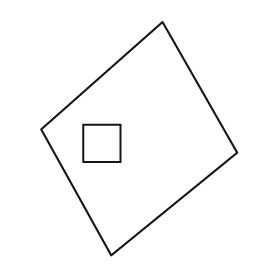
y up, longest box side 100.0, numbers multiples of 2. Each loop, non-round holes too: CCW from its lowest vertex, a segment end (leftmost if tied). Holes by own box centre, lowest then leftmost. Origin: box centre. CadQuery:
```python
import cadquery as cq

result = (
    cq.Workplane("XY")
    .moveTo(-12.0, -50.0)
    .lineTo(42.0, -6.0)
    .lineTo(10.0, 50.0)
    .lineTo(-42.0, 4.0)
    .close()
    .moveTo(-24.0, -10.0)
    .lineTo(-8.0, -10.0)
    .lineTo(-8.0, 6.0)
    .lineTo(-24.0, 6.0)
    .close()
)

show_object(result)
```